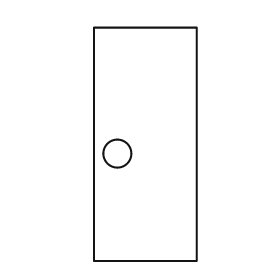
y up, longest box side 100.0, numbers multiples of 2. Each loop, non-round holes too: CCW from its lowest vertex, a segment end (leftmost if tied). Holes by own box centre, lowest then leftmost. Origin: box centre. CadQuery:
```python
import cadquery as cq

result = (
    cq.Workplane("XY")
    .moveTo(-22.0, -50.0)
    .lineTo(22.0, -50.0)
    .lineTo(22.0, 50.0)
    .lineTo(-22.0, 50.0)
    .close()
    .moveTo(-12.0, -4.0)
    .circle(6.0)
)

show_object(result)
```